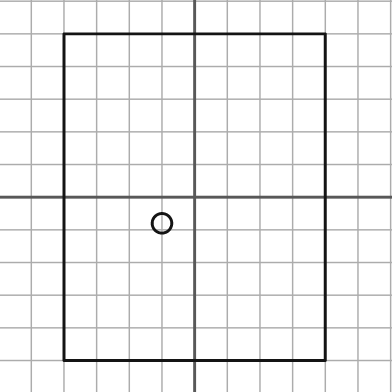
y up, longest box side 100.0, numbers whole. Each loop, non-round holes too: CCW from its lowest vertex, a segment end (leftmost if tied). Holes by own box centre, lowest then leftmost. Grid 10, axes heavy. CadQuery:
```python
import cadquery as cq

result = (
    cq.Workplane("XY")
    .moveTo(-40.0, -50.0)
    .lineTo(40.0, -50.0)
    .lineTo(40.0, 50.0)
    .lineTo(-40.0, 50.0)
    .close()
    .moveTo(-10.0, -8.0)
    .circle(3.0)
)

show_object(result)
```